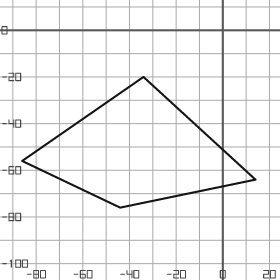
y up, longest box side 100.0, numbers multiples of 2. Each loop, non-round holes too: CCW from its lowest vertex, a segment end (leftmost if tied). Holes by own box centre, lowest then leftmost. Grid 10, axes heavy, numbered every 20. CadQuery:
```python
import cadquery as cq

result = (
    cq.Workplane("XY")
    .moveTo(-44.0, -76.0)
    .lineTo(14.0, -64.0)
    .lineTo(-34.0, -20.0)
    .lineTo(-86.0, -56.0)
    .close()
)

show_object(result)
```